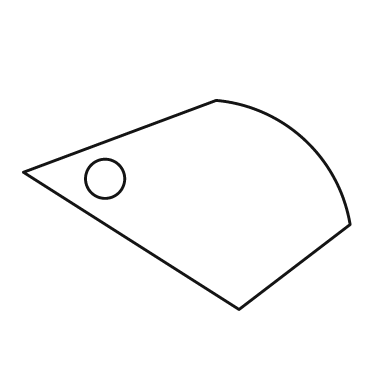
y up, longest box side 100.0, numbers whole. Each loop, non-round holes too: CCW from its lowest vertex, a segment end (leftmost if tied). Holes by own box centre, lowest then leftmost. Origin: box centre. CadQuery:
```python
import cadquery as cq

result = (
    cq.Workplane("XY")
    .moveTo(16.0, -32.0)
    .lineTo(50.0, -6.0)
    .threePointArc((36.0, 20.0), (9.0, 32.0))
    .lineTo(-50.0, 10.0)
    .close()
    .moveTo(-25.0, 8.0)
    .circle(6.0)
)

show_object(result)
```